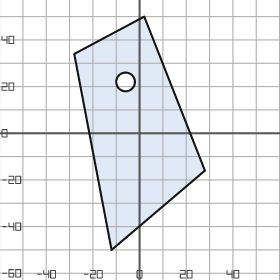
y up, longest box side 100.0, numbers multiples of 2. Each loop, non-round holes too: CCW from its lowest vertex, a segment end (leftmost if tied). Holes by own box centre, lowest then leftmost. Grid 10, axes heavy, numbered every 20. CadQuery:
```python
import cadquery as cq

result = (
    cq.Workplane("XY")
    .moveTo(-12.0, -50.0)
    .lineTo(28.0, -16.0)
    .lineTo(2.0, 50.0)
    .lineTo(-28.0, 34.0)
    .close()
    .moveTo(-6.0, 22.0)
    .circle(4.0)
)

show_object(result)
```